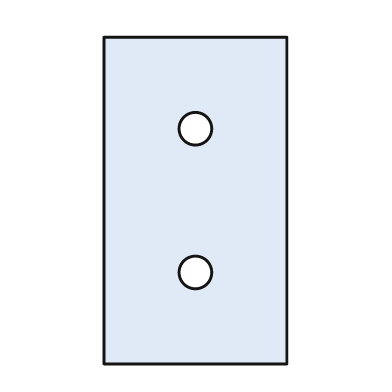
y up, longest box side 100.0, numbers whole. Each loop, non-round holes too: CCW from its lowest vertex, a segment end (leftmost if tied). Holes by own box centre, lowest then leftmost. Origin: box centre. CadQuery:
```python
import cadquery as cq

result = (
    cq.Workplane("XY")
    .moveTo(-28.0, -50.0)
    .lineTo(28.0, -50.0)
    .lineTo(28.0, 50.0)
    .lineTo(-28.0, 50.0)
    .close()
    .moveTo(0.0, -22.0)
    .circle(5.0)
    .moveTo(0.0, 22.0)
    .circle(5.0)
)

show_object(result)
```